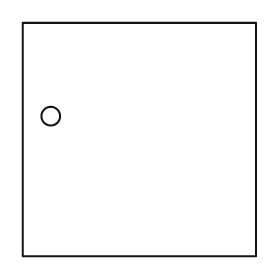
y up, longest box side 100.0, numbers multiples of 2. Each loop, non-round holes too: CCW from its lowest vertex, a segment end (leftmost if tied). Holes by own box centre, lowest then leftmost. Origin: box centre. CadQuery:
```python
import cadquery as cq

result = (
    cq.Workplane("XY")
    .moveTo(-50.0, -50.0)
    .lineTo(50.0, -50.0)
    .lineTo(50.0, 50.0)
    .lineTo(-50.0, 50.0)
    .close()
    .moveTo(-38.0, 10.0)
    .circle(4.0)
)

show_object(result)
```